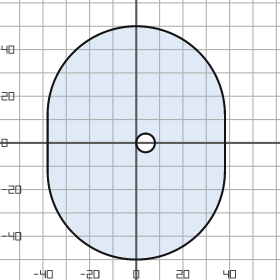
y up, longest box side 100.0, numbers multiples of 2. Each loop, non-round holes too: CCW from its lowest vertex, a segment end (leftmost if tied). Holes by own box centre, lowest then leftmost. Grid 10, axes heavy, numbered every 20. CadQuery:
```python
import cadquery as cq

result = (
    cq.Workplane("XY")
    .moveTo(-38.0, -12.0)
    .threePointArc((0.0, -50.0), (38.0, -12.0))
    .lineTo(38.0, 12.0)
    .threePointArc((0.0, 50.0), (-38.0, 12.0))
    .close()
    .moveTo(4.0, 0.0)
    .circle(4.0)
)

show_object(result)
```